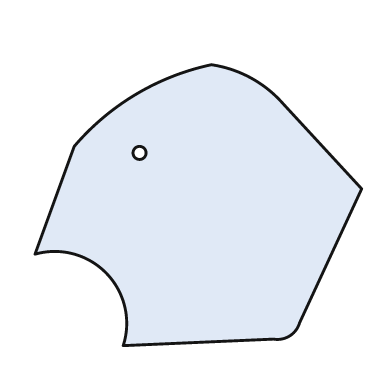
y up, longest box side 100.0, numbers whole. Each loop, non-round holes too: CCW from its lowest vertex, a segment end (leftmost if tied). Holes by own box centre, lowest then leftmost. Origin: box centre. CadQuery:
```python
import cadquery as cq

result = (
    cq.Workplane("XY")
    .moveTo(-23.0, -43.0)
    .lineTo(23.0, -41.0)
    .threePointArc((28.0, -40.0), (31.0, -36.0))
    .lineTo(50.0, 5.0)
    .lineTo(26.0, 31.0)
    .threePointArc((16.0, 39.0), (4.0, 43.0))
    .threePointArc((-19.0, 34.0), (-38.0, 18.0))
    .lineTo(-50.0, -15.0)
    .threePointArc((-28.0, -21.0), (-23.0, -43.0))
    .close()
    .moveTo(-18.0, 16.0)
    .circle(2.0)
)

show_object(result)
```